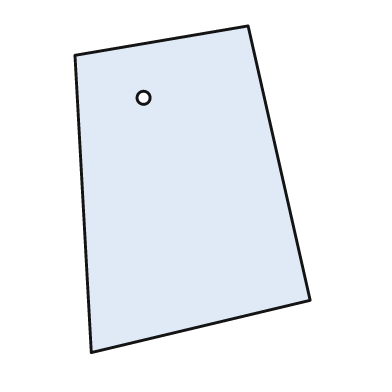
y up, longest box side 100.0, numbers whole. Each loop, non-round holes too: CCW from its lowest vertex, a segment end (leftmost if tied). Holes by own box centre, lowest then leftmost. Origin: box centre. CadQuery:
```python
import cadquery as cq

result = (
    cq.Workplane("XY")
    .moveTo(-31.0, -50.0)
    .lineTo(36.0, -34.0)
    .lineTo(17.0, 50.0)
    .lineTo(-36.0, 41.0)
    .close()
    .moveTo(-15.0, 28.0)
    .circle(2.0)
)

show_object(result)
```